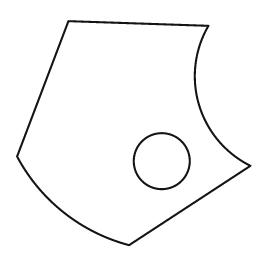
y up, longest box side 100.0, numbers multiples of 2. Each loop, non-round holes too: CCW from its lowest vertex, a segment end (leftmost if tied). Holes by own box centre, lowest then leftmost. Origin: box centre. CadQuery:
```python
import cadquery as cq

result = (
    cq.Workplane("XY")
    .moveTo(-2.0, -48.0)
    .lineTo(50.0, -14.0)
    .threePointArc((28.0, 12.0), (32.0, 46.0))
    .lineTo(-28.0, 48.0)
    .lineTo(-50.0, -10.0)
    .threePointArc((-30.0, -34.0), (-2.0, -48.0))
    .close()
    .moveTo(12.0, -12.0)
    .circle(12.0)
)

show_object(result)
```